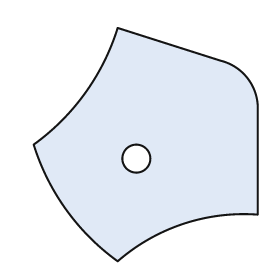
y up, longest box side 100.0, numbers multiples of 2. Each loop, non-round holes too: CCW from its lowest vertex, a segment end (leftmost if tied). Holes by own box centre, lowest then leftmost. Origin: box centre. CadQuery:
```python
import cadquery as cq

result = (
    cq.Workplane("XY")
    .moveTo(-12.0, -50.0)
    .threePointArc((16.0, -34.0), (48.0, -30.0))
    .lineTo(48.0, 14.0)
    .threePointArc((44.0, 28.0), (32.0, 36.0))
    .lineTo(-12.0, 50.0)
    .threePointArc((-26.0, 22.0), (-48.0, 0.0))
    .threePointArc((-34.0, -28.0), (-12.0, -50.0))
    .close()
    .moveTo(-4.0, -6.0)
    .circle(6.0)
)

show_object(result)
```